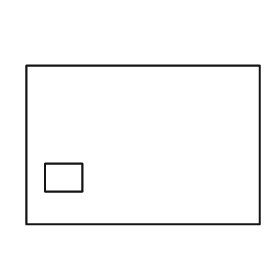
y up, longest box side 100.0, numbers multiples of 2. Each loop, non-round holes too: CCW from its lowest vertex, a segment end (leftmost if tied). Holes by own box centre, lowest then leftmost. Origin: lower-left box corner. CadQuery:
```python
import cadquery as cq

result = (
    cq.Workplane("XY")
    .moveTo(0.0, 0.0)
    .lineTo(100.0, 0.0)
    .lineTo(100.0, 68.0)
    .lineTo(0.0, 68.0)
    .close()
    .moveTo(8.0, 14.0)
    .lineTo(24.0, 14.0)
    .lineTo(24.0, 26.0)
    .lineTo(8.0, 26.0)
    .close()
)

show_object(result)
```